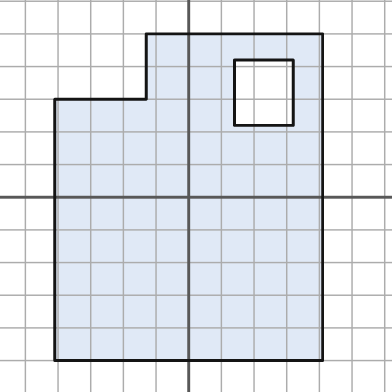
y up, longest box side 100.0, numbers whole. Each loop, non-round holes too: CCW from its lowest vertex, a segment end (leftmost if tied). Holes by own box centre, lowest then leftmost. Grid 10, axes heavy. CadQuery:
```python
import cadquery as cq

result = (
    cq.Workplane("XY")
    .moveTo(-41.0, -50.0)
    .lineTo(41.0, -50.0)
    .lineTo(41.0, 50.0)
    .lineTo(-13.0, 50.0)
    .lineTo(-13.0, 30.0)
    .lineTo(-41.0, 30.0)
    .close()
    .moveTo(14.0, 22.0)
    .lineTo(32.0, 22.0)
    .lineTo(32.0, 42.0)
    .lineTo(14.0, 42.0)
    .close()
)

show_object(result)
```